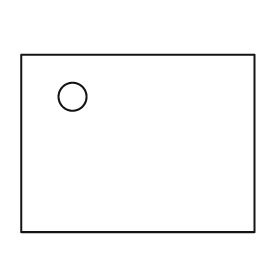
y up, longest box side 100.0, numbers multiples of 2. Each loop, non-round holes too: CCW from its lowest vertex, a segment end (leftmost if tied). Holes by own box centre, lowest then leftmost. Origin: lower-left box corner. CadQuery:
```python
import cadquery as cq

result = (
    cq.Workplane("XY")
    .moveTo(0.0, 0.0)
    .lineTo(100.0, 0.0)
    .lineTo(100.0, 76.0)
    .lineTo(0.0, 76.0)
    .close()
    .moveTo(22.0, 58.0)
    .circle(6.0)
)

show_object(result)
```